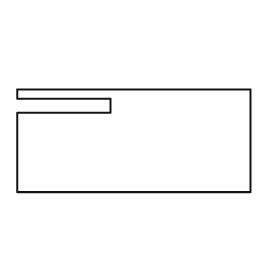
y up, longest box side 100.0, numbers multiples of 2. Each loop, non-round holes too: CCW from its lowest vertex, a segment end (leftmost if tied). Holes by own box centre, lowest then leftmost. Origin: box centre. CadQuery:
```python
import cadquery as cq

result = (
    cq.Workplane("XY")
    .moveTo(-50.0, -22.0)
    .lineTo(50.0, -22.0)
    .lineTo(50.0, 22.0)
    .lineTo(-50.0, 22.0)
    .lineTo(-50.0, 18.0)
    .lineTo(-10.0, 18.0)
    .lineTo(-10.0, 12.0)
    .lineTo(-50.0, 12.0)
    .close()
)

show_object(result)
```